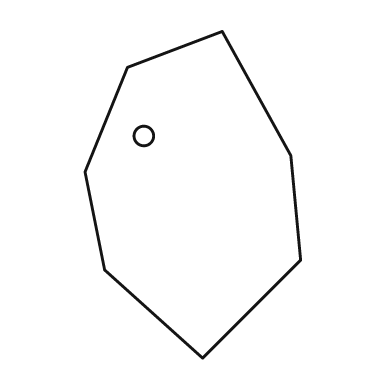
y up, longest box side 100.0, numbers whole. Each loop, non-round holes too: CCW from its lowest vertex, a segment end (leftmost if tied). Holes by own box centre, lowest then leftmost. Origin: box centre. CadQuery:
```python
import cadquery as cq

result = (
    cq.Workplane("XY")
    .moveTo(3.0, -50.0)
    .lineTo(33.0, -20.0)
    .lineTo(30.0, 12.0)
    .lineTo(9.0, 50.0)
    .lineTo(-20.0, 39.0)
    .lineTo(-33.0, 7.0)
    .lineTo(-27.0, -23.0)
    .close()
    .moveTo(-15.0, 18.0)
    .circle(3.0)
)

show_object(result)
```